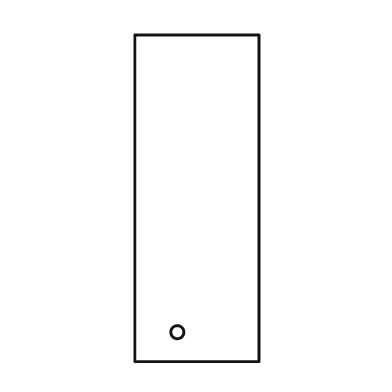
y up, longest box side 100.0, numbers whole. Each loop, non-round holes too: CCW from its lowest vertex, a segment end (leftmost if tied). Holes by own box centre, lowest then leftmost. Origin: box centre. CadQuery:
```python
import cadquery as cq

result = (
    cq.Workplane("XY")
    .moveTo(-19.0, -50.0)
    .lineTo(19.0, -50.0)
    .lineTo(19.0, 50.0)
    .lineTo(-19.0, 50.0)
    .close()
    .moveTo(-6.0, -41.0)
    .circle(2.0)
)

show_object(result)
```